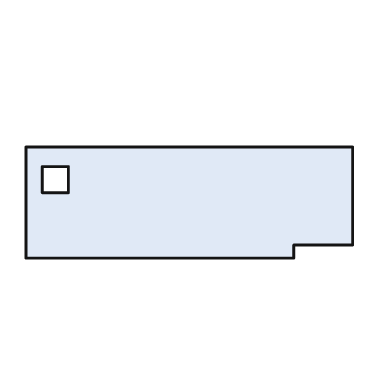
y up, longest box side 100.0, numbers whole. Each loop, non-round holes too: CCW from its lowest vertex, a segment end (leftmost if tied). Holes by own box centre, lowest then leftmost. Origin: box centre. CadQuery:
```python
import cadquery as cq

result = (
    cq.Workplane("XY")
    .moveTo(-50.0, -17.0)
    .lineTo(32.0, -17.0)
    .lineTo(32.0, -13.0)
    .lineTo(50.0, -13.0)
    .lineTo(50.0, 17.0)
    .lineTo(-50.0, 17.0)
    .close()
    .moveTo(-45.0, 3.0)
    .lineTo(-37.0, 3.0)
    .lineTo(-37.0, 11.0)
    .lineTo(-45.0, 11.0)
    .close()
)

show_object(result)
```